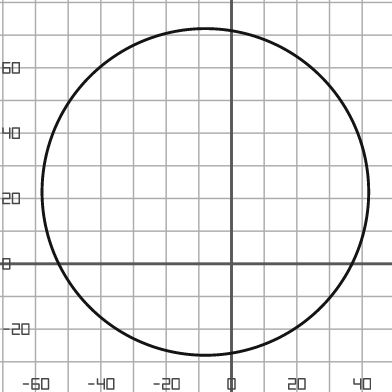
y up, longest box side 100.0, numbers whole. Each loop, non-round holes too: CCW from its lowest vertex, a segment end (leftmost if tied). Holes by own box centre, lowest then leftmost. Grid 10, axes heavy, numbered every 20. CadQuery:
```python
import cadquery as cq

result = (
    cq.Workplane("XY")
    .moveTo(-8.0, 22.0)
    .circle(50.0)
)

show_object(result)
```